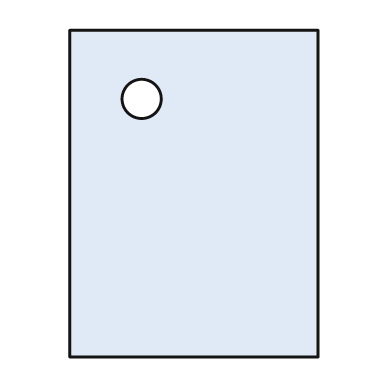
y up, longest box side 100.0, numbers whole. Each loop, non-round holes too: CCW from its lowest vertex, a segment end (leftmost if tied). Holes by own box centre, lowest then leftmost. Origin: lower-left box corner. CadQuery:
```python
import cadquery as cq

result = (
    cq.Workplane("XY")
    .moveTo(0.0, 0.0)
    .lineTo(76.0, 0.0)
    .lineTo(76.0, 100.0)
    .lineTo(0.0, 100.0)
    .close()
    .moveTo(22.0, 79.0)
    .circle(6.0)
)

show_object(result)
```